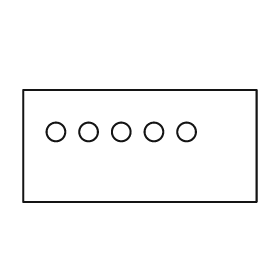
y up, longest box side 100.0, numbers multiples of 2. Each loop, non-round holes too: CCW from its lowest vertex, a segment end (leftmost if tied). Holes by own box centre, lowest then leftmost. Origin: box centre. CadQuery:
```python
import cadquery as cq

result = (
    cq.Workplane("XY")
    .moveTo(-50.0, -24.0)
    .lineTo(50.0, -24.0)
    .lineTo(50.0, 24.0)
    .lineTo(-50.0, 24.0)
    .close()
    .moveTo(-36.0, 6.0)
    .circle(4.0)
    .moveTo(-22.0, 6.0)
    .circle(4.0)
    .moveTo(-8.0, 6.0)
    .circle(4.0)
    .moveTo(6.0, 6.0)
    .circle(4.0)
    .moveTo(20.0, 6.0)
    .circle(4.0)
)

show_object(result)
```